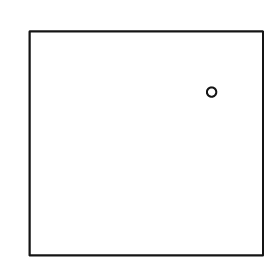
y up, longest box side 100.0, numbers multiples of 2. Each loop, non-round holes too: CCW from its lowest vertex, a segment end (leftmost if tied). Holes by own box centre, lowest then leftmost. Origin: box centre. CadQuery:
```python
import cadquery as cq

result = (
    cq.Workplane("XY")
    .moveTo(-50.0, -48.0)
    .lineTo(50.0, -48.0)
    .lineTo(50.0, 48.0)
    .lineTo(-50.0, 48.0)
    .close()
    .moveTo(28.0, 22.0)
    .circle(2.0)
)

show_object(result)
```